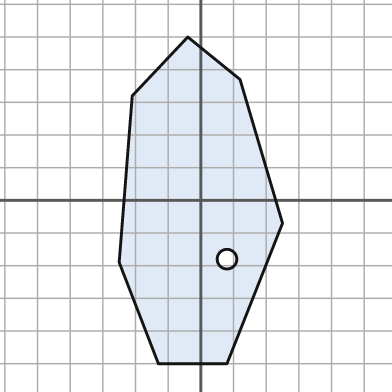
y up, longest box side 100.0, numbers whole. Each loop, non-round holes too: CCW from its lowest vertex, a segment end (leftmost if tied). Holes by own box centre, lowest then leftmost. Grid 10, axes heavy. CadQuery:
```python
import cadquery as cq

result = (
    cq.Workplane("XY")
    .moveTo(-13.0, -50.0)
    .lineTo(8.0, -50.0)
    .lineTo(25.0, -7.0)
    .lineTo(12.0, 37.0)
    .lineTo(-4.0, 50.0)
    .lineTo(-21.0, 32.0)
    .lineTo(-25.0, -19.0)
    .close()
    .moveTo(8.0, -18.0)
    .circle(3.0)
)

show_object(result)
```